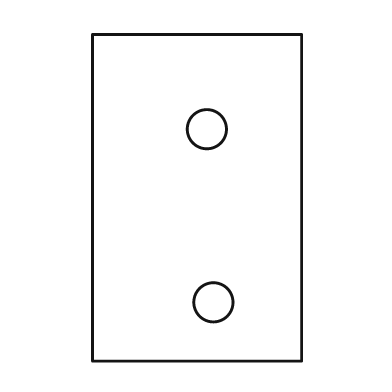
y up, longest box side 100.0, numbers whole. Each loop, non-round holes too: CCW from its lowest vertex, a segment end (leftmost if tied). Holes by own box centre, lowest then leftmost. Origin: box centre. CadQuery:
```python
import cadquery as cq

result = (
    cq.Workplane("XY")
    .moveTo(-32.0, -50.0)
    .lineTo(32.0, -50.0)
    .lineTo(32.0, 50.0)
    .lineTo(-32.0, 50.0)
    .close()
    .moveTo(5.0, -32.0)
    .circle(6.0)
    .moveTo(3.0, 21.0)
    .circle(6.0)
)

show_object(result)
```